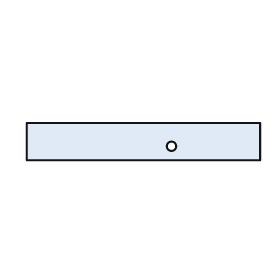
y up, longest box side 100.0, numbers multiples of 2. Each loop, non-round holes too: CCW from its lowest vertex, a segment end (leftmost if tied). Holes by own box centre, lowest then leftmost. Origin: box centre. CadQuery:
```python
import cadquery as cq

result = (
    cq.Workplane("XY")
    .moveTo(-50.0, -8.0)
    .lineTo(50.0, -8.0)
    .lineTo(50.0, 8.0)
    .lineTo(-50.0, 8.0)
    .close()
    .moveTo(12.0, -2.0)
    .circle(2.0)
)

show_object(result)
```